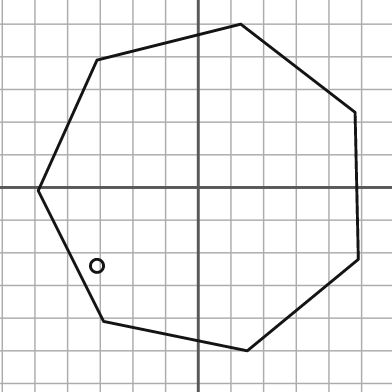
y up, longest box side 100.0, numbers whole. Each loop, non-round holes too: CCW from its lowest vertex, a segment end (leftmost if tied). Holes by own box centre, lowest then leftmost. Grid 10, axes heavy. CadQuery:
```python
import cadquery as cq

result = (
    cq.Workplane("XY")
    .moveTo(15.0, -50.0)
    .lineTo(49.0, -22.0)
    .lineTo(48.0, 23.0)
    .lineTo(13.0, 50.0)
    .lineTo(-31.0, 39.0)
    .lineTo(-49.0, -1.0)
    .lineTo(-29.0, -41.0)
    .close()
    .moveTo(-31.0, -24.0)
    .circle(2.0)
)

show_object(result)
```